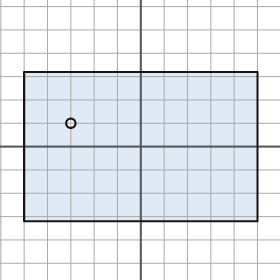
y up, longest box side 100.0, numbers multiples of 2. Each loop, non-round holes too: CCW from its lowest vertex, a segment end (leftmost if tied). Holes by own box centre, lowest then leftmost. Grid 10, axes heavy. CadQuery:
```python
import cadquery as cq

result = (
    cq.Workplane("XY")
    .moveTo(-50.0, -32.0)
    .lineTo(50.0, -32.0)
    .lineTo(50.0, 32.0)
    .lineTo(-50.0, 32.0)
    .close()
    .moveTo(-30.0, 10.0)
    .circle(2.0)
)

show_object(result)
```